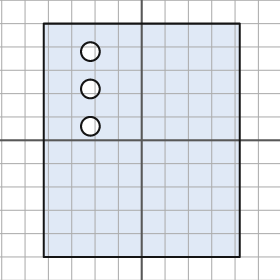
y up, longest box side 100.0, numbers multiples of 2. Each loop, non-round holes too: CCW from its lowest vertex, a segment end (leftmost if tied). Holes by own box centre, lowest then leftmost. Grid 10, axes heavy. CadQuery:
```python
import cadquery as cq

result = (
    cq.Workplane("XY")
    .moveTo(-42.0, -50.0)
    .lineTo(42.0, -50.0)
    .lineTo(42.0, 50.0)
    .lineTo(-42.0, 50.0)
    .close()
    .moveTo(-22.0, 6.0)
    .circle(4.0)
    .moveTo(-22.0, 22.0)
    .circle(4.0)
    .moveTo(-22.0, 38.0)
    .circle(4.0)
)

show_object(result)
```